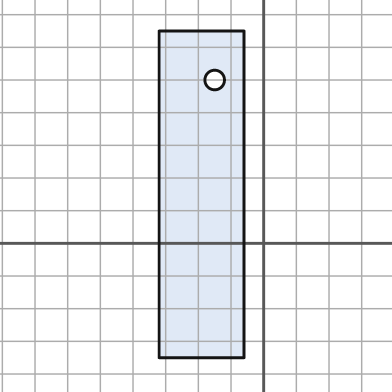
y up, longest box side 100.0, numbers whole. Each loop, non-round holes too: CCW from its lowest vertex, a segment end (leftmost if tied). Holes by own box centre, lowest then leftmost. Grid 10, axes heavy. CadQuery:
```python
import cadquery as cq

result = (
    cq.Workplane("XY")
    .moveTo(-32.0, -35.0)
    .lineTo(-6.0, -35.0)
    .lineTo(-6.0, 65.0)
    .lineTo(-32.0, 65.0)
    .close()
    .moveTo(-15.0, 50.0)
    .circle(3.0)
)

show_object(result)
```